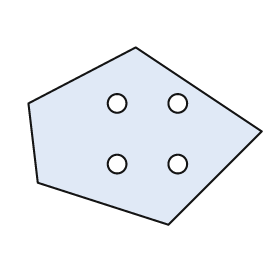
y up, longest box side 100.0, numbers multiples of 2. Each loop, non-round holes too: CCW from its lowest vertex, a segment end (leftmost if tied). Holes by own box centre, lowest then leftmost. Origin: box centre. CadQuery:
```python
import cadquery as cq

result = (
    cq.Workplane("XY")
    .moveTo(10.0, -38.0)
    .lineTo(50.0, 2.0)
    .lineTo(-4.0, 38.0)
    .lineTo(-50.0, 14.0)
    .lineTo(-46.0, -20.0)
    .close()
    .moveTo(-12.0, -12.0)
    .circle(4.0)
    .moveTo(14.0, -12.0)
    .circle(4.0)
    .moveTo(-12.0, 14.0)
    .circle(4.0)
    .moveTo(14.0, 14.0)
    .circle(4.0)
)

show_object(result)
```